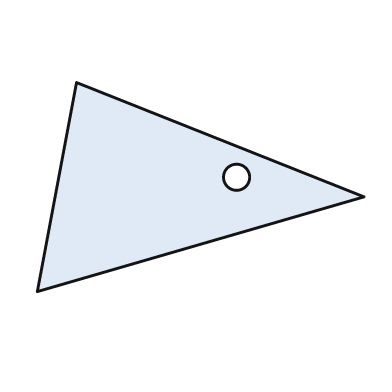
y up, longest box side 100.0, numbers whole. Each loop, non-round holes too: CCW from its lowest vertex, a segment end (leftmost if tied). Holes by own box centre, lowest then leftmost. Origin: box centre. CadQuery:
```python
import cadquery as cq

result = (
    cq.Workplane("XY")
    .moveTo(-50.0, -32.0)
    .lineTo(50.0, -3.0)
    .lineTo(-38.0, 32.0)
    .close()
    .moveTo(11.0, 3.0)
    .circle(4.0)
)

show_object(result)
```